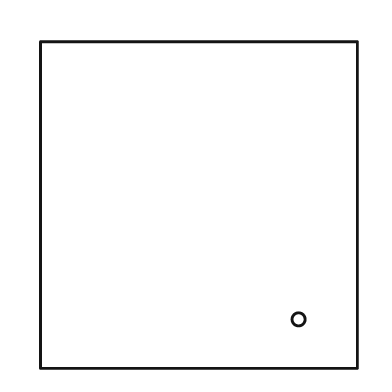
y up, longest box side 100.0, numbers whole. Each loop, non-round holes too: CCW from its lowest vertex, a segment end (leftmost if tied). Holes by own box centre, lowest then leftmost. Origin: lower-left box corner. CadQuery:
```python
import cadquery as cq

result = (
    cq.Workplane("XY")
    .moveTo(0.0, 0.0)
    .lineTo(97.0, 0.0)
    .lineTo(97.0, 100.0)
    .lineTo(0.0, 100.0)
    .close()
    .moveTo(79.0, 15.0)
    .circle(2.0)
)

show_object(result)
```